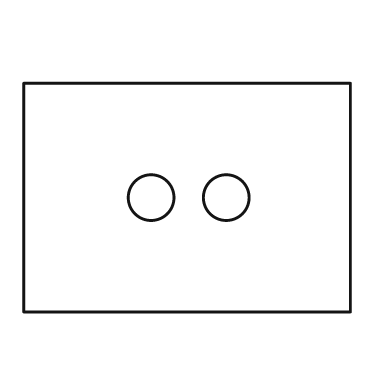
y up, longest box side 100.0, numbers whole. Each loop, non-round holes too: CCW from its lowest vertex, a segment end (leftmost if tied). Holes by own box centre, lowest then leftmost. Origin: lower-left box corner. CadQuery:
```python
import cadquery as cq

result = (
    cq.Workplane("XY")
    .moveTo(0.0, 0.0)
    .lineTo(100.0, 0.0)
    .lineTo(100.0, 70.0)
    .lineTo(0.0, 70.0)
    .close()
    .moveTo(39.0, 35.0)
    .circle(7.0)
    .moveTo(62.0, 35.0)
    .circle(7.0)
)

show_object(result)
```